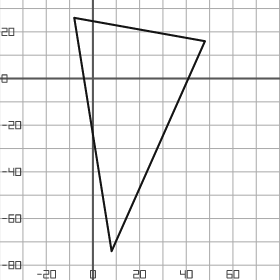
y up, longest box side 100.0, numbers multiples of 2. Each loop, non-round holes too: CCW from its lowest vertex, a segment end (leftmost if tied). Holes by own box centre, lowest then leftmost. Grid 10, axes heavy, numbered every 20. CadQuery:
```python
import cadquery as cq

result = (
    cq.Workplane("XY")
    .moveTo(8.0, -74.0)
    .lineTo(48.0, 16.0)
    .lineTo(-8.0, 26.0)
    .close()
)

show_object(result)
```